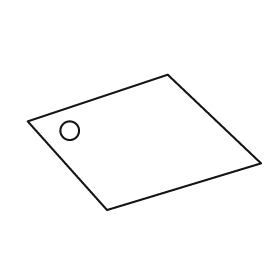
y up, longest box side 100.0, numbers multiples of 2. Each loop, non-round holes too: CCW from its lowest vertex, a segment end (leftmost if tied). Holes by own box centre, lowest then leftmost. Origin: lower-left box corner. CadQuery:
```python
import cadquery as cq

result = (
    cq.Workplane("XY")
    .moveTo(34.0, 0.0)
    .lineTo(100.0, 20.0)
    .lineTo(60.0, 58.0)
    .lineTo(0.0, 38.0)
    .close()
    .moveTo(18.0, 34.0)
    .circle(4.0)
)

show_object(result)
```